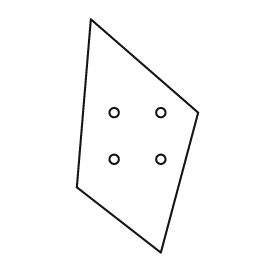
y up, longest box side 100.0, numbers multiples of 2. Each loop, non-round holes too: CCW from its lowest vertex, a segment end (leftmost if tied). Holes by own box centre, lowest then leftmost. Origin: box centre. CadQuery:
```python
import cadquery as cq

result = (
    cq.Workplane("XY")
    .moveTo(10.0, -50.0)
    .lineTo(26.0, 10.0)
    .lineTo(-20.0, 50.0)
    .lineTo(-26.0, -22.0)
    .close()
    .moveTo(-10.0, -10.0)
    .circle(2.0)
    .moveTo(10.0, -10.0)
    .circle(2.0)
    .moveTo(-10.0, 10.0)
    .circle(2.0)
    .moveTo(10.0, 10.0)
    .circle(2.0)
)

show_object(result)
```